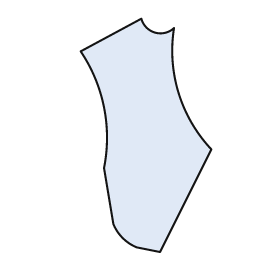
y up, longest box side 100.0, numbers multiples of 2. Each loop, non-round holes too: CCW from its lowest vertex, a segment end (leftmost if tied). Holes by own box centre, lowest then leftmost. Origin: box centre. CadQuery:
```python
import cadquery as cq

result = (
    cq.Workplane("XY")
    .moveTo(6.0, -50.0)
    .lineTo(28.0, -6.0)
    .threePointArc((14.0, 18.0), (12.0, 46.0))
    .threePointArc((4.0, 44.0), (-2.0, 50.0))
    .lineTo(-28.0, 36.0)
    .threePointArc((-18.0, 12.0), (-18.0, -14.0))
    .lineTo(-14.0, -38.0)
    .threePointArc((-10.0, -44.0), (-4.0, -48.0))
    .close()
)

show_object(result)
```